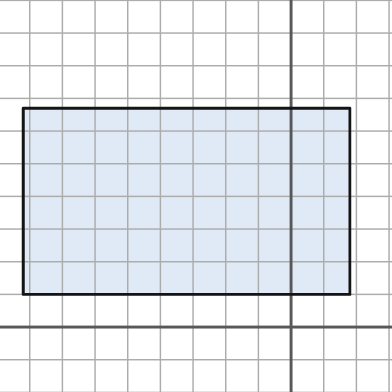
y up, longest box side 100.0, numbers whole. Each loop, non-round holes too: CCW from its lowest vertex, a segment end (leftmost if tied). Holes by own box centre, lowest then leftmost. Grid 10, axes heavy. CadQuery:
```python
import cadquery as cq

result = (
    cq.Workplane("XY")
    .moveTo(-82.0, 10.0)
    .lineTo(18.0, 10.0)
    .lineTo(18.0, 67.0)
    .lineTo(-82.0, 67.0)
    .close()
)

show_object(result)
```